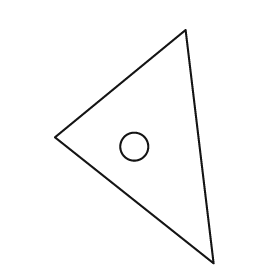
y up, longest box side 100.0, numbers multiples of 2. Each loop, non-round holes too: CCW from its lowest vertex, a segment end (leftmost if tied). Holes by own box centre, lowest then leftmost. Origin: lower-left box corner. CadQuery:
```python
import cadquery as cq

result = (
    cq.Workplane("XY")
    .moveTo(68.0, 0.0)
    .lineTo(56.0, 100.0)
    .lineTo(0.0, 54.0)
    .close()
    .moveTo(34.0, 50.0)
    .circle(6.0)
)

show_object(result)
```